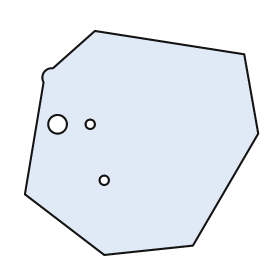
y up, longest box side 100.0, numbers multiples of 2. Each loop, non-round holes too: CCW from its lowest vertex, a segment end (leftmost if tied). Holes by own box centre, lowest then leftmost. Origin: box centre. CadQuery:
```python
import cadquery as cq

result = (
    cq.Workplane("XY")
    .moveTo(-16.0, -48.0)
    .lineTo(22.0, -44.0)
    .lineTo(50.0, 4.0)
    .lineTo(44.0, 38.0)
    .lineTo(-20.0, 48.0)
    .lineTo(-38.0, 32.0)
    .threePointArc((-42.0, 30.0), (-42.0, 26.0))
    .lineTo(-50.0, -22.0)
    .close()
    .moveTo(-16.0, -16.0)
    .circle(2.0)
    .moveTo(-36.0, 8.0)
    .circle(4.0)
    .moveTo(-22.0, 8.0)
    .circle(2.0)
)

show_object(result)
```